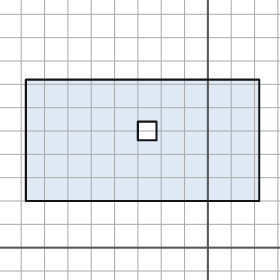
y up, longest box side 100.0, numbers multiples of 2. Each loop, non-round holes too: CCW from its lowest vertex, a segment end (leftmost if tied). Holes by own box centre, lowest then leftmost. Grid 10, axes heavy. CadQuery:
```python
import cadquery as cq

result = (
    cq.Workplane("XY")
    .moveTo(-78.0, 20.0)
    .lineTo(22.0, 20.0)
    .lineTo(22.0, 72.0)
    .lineTo(-78.0, 72.0)
    .close()
    .moveTo(-30.0, 46.0)
    .lineTo(-22.0, 46.0)
    .lineTo(-22.0, 54.0)
    .lineTo(-30.0, 54.0)
    .close()
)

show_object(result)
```